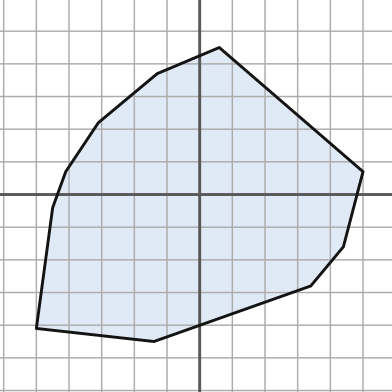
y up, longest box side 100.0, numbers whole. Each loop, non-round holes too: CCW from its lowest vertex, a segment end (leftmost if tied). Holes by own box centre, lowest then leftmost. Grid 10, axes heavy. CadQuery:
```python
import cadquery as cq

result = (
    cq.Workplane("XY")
    .moveTo(-14.0, -45.0)
    .lineTo(34.0, -28.0)
    .lineTo(44.0, -16.0)
    .lineTo(50.0, 7.0)
    .lineTo(6.0, 45.0)
    .lineTo(-13.0, 37.0)
    .lineTo(-31.0, 22.0)
    .lineTo(-41.0, 7.0)
    .lineTo(-45.0, -4.0)
    .lineTo(-50.0, -41.0)
    .close()
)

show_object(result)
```